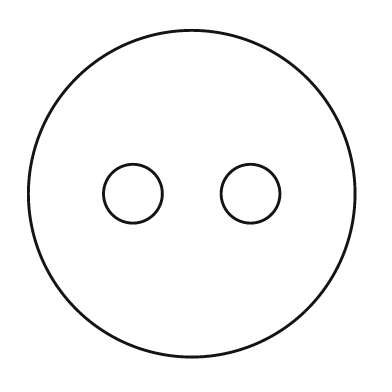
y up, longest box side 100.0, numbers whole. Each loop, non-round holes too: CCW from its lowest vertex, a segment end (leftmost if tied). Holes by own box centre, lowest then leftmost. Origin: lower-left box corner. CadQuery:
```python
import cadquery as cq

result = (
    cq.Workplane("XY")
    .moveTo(50.0, 50.0)
    .circle(50.0)
    .moveTo(32.0, 50.0)
    .circle(9.0)
    .moveTo(68.0, 50.0)
    .circle(9.0)
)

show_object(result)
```